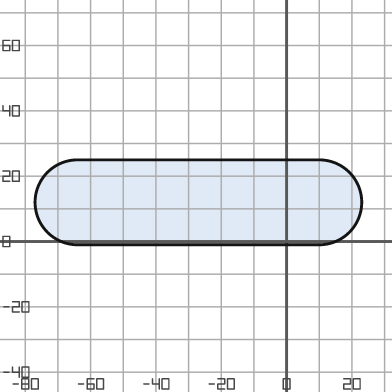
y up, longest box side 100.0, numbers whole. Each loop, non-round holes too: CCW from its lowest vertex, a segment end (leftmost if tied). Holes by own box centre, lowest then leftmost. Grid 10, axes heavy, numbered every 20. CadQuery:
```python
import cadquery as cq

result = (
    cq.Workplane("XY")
    .moveTo(-64.0, -1.0)
    .lineTo(10.0, -1.0)
    .threePointArc((23.0, 12.0), (10.0, 25.0))
    .lineTo(-64.0, 25.0)
    .threePointArc((-77.0, 12.0), (-64.0, -1.0))
    .close()
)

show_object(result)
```